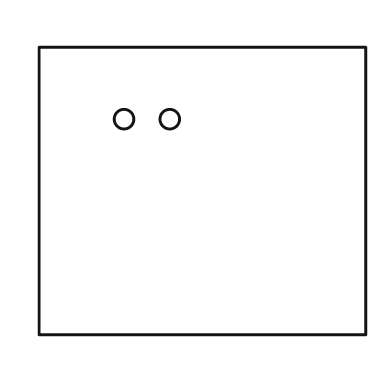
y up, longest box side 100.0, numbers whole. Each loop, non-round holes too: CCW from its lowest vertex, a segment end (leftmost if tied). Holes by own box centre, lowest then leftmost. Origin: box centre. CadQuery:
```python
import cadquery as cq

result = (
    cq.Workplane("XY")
    .moveTo(-50.0, -44.0)
    .lineTo(50.0, -44.0)
    .lineTo(50.0, 44.0)
    .lineTo(-50.0, 44.0)
    .close()
    .moveTo(-24.0, 22.0)
    .circle(3.0)
    .moveTo(-10.0, 22.0)
    .circle(3.0)
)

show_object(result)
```